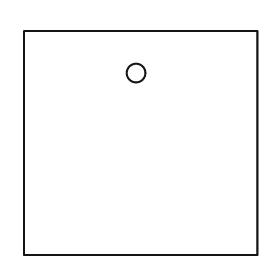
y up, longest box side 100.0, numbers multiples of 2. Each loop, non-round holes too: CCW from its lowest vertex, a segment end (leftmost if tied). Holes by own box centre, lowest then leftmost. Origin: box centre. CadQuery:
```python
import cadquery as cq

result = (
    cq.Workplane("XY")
    .moveTo(-50.0, -48.0)
    .lineTo(50.0, -48.0)
    .lineTo(50.0, 48.0)
    .lineTo(-50.0, 48.0)
    .close()
    .moveTo(-2.0, 30.0)
    .circle(4.0)
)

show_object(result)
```